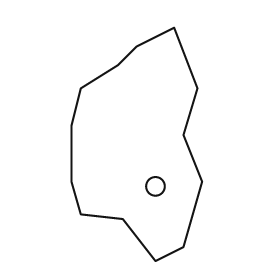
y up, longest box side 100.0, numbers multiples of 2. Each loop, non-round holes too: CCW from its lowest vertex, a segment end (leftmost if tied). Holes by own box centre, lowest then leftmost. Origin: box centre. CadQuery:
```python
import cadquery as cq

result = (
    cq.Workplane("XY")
    .moveTo(8.0, -50.0)
    .lineTo(20.0, -44.0)
    .lineTo(28.0, -16.0)
    .lineTo(20.0, 4.0)
    .lineTo(26.0, 24.0)
    .lineTo(16.0, 50.0)
    .lineTo(0.0, 42.0)
    .lineTo(-8.0, 34.0)
    .lineTo(-24.0, 24.0)
    .lineTo(-28.0, 8.0)
    .lineTo(-28.0, -16.0)
    .lineTo(-24.0, -30.0)
    .lineTo(-6.0, -32.0)
    .close()
    .moveTo(8.0, -18.0)
    .circle(4.0)
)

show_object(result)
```